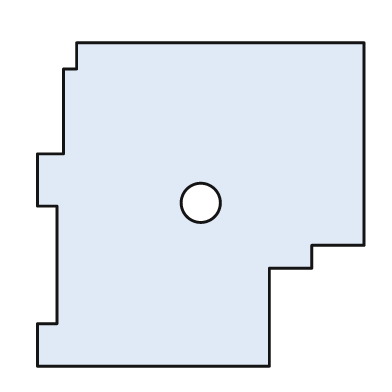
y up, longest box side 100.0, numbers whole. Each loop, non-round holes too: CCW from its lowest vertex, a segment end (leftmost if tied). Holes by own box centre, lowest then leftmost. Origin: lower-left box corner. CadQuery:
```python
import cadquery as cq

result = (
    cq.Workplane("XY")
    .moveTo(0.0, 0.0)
    .lineTo(71.0, 0.0)
    .lineTo(71.0, 30.0)
    .lineTo(84.0, 30.0)
    .lineTo(84.0, 37.0)
    .lineTo(100.0, 37.0)
    .lineTo(100.0, 99.0)
    .lineTo(12.0, 99.0)
    .lineTo(12.0, 91.0)
    .lineTo(8.0, 91.0)
    .lineTo(8.0, 65.0)
    .lineTo(0.0, 65.0)
    .lineTo(0.0, 49.0)
    .lineTo(6.0, 49.0)
    .lineTo(6.0, 13.0)
    .lineTo(0.0, 13.0)
    .close()
    .moveTo(50.0, 50.0)
    .circle(6.0)
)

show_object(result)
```